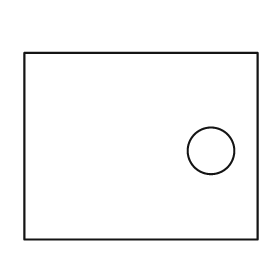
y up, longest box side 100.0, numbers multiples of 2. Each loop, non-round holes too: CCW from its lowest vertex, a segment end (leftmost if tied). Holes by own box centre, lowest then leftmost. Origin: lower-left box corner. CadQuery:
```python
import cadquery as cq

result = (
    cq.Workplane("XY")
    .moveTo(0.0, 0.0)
    .lineTo(100.0, 0.0)
    .lineTo(100.0, 80.0)
    .lineTo(0.0, 80.0)
    .close()
    .moveTo(80.0, 38.0)
    .circle(10.0)
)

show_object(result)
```